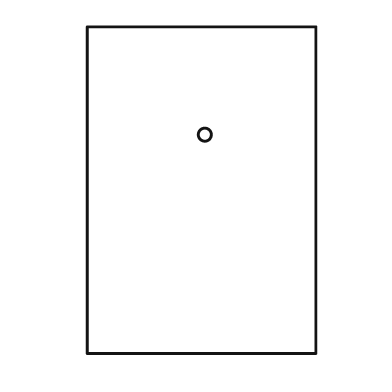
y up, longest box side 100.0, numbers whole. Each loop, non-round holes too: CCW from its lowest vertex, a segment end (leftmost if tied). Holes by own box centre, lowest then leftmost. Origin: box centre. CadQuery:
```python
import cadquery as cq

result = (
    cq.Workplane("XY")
    .moveTo(-35.0, -50.0)
    .lineTo(35.0, -50.0)
    .lineTo(35.0, 50.0)
    .lineTo(-35.0, 50.0)
    .close()
    .moveTo(1.0, 17.0)
    .circle(2.0)
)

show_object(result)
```